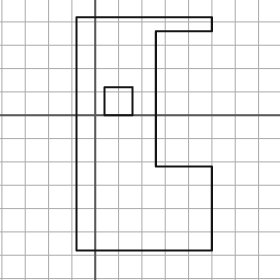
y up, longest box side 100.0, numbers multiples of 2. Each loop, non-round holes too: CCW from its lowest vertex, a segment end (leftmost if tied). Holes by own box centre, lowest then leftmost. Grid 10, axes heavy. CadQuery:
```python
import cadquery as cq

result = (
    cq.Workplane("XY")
    .moveTo(-8.0, -58.0)
    .lineTo(50.0, -58.0)
    .lineTo(50.0, -22.0)
    .lineTo(26.0, -22.0)
    .lineTo(26.0, 36.0)
    .lineTo(50.0, 36.0)
    .lineTo(50.0, 42.0)
    .lineTo(-8.0, 42.0)
    .close()
    .moveTo(4.0, 0.0)
    .lineTo(16.0, 0.0)
    .lineTo(16.0, 12.0)
    .lineTo(4.0, 12.0)
    .close()
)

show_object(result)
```